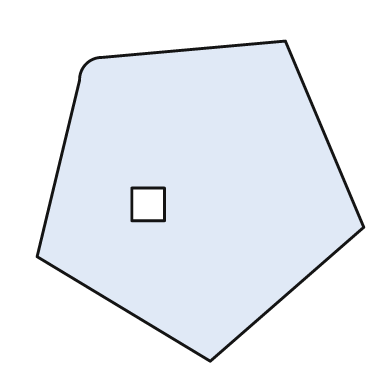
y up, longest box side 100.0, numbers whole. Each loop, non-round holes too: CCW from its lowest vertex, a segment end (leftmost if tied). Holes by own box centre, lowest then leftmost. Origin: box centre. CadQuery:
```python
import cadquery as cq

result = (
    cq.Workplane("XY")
    .moveTo(3.0, -49.0)
    .lineTo(50.0, -8.0)
    .lineTo(26.0, 49.0)
    .lineTo(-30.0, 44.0)
    .threePointArc((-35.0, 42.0), (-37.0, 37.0))
    .lineTo(-50.0, -17.0)
    .close()
    .moveTo(-21.0, -6.0)
    .lineTo(-11.0, -6.0)
    .lineTo(-11.0, 4.0)
    .lineTo(-21.0, 4.0)
    .close()
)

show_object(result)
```